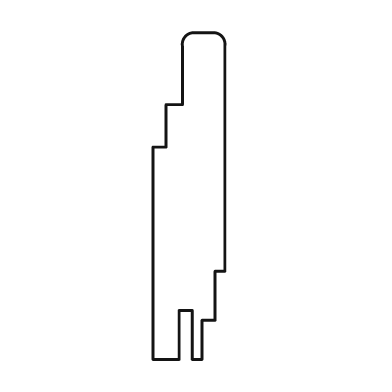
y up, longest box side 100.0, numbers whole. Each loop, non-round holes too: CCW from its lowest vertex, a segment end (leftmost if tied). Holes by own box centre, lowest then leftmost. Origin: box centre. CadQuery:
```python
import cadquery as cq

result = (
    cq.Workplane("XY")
    .moveTo(-11.0, -50.0)
    .lineTo(-3.0, -50.0)
    .lineTo(-3.0, -35.0)
    .lineTo(1.0, -35.0)
    .lineTo(1.0, -50.0)
    .lineTo(4.0, -50.0)
    .lineTo(4.0, -38.0)
    .lineTo(8.0, -38.0)
    .lineTo(8.0, -23.0)
    .lineTo(11.0, -23.0)
    .lineTo(11.0, 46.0)
    .threePointArc((10.0, 49.0), (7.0, 50.0))
    .lineTo(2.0, 50.0)
    .threePointArc((-1.0, 49.0), (-2.0, 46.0))
    .lineTo(-2.0, 28.0)
    .lineTo(-7.0, 28.0)
    .lineTo(-7.0, 15.0)
    .lineTo(-11.0, 15.0)
    .close()
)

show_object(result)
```